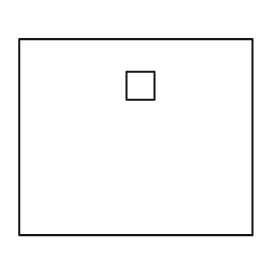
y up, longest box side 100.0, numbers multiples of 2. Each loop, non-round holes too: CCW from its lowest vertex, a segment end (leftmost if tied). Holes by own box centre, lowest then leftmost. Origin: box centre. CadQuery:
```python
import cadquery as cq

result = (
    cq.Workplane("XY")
    .moveTo(-50.0, -42.0)
    .lineTo(50.0, -42.0)
    .lineTo(50.0, 42.0)
    .lineTo(-50.0, 42.0)
    .close()
    .moveTo(-4.0, 16.0)
    .lineTo(8.0, 16.0)
    .lineTo(8.0, 28.0)
    .lineTo(-4.0, 28.0)
    .close()
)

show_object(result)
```